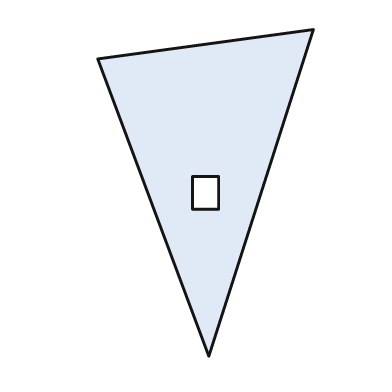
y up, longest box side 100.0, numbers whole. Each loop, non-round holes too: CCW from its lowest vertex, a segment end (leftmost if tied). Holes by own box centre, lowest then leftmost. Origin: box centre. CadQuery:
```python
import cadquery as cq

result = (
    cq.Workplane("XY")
    .moveTo(1.0, -50.0)
    .lineTo(33.0, 50.0)
    .lineTo(-33.0, 41.0)
    .close()
    .moveTo(-4.0, -5.0)
    .lineTo(4.0, -5.0)
    .lineTo(4.0, 5.0)
    .lineTo(-4.0, 5.0)
    .close()
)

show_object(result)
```